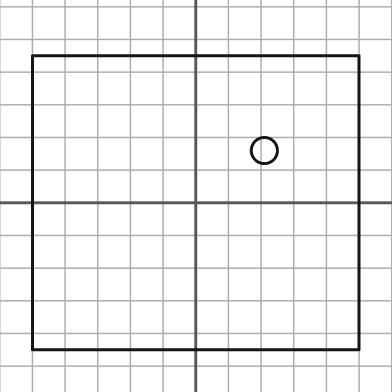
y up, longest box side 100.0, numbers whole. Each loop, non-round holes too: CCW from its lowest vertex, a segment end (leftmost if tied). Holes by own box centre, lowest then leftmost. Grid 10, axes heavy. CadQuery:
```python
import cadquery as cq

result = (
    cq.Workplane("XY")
    .moveTo(-50.0, -45.0)
    .lineTo(50.0, -45.0)
    .lineTo(50.0, 45.0)
    .lineTo(-50.0, 45.0)
    .close()
    .moveTo(21.0, 16.0)
    .circle(4.0)
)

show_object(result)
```